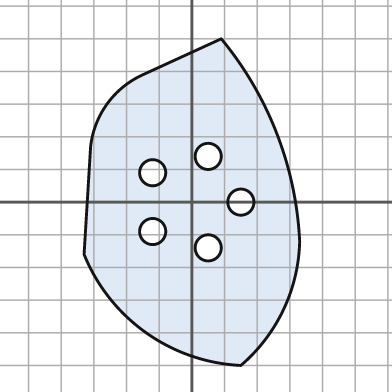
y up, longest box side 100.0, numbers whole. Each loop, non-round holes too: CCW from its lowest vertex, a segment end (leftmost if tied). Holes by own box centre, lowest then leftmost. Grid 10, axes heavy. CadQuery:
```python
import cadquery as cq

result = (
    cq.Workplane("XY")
    .moveTo(15.0, -50.0)
    .threePointArc((28.0, -33.0), (33.0, -12.0))
    .threePointArc((26.0, 21.0), (9.0, 50.0))
    .lineTo(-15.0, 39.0)
    .threePointArc((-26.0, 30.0), (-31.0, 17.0))
    .lineTo(-33.0, -16.0)
    .threePointArc((-14.0, -40.0), (15.0, -50.0))
    .close()
    .moveTo(5.0, -14.0)
    .circle(4.0)
    .moveTo(-12.0, -9.0)
    .circle(4.0)
    .moveTo(15.0, 0.0)
    .circle(4.0)
    .moveTo(-12.0, 9.0)
    .circle(4.0)
    .moveTo(5.0, 14.0)
    .circle(4.0)
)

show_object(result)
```